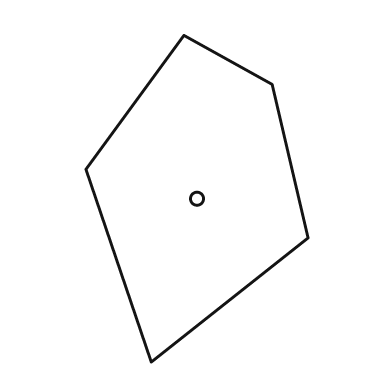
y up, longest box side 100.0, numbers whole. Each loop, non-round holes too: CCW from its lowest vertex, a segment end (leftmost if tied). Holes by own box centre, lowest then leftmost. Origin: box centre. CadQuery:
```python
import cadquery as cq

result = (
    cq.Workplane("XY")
    .moveTo(-14.0, -50.0)
    .lineTo(34.0, -12.0)
    .lineTo(23.0, 35.0)
    .lineTo(-4.0, 50.0)
    .lineTo(-34.0, 9.0)
    .close()
    .moveTo(0.0, 0.0)
    .circle(2.0)
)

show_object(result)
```